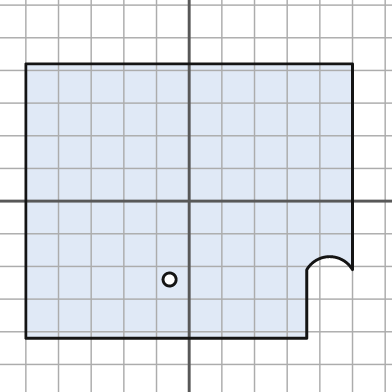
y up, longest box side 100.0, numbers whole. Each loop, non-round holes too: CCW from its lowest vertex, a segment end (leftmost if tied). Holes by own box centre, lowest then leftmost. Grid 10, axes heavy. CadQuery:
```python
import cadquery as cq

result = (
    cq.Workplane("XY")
    .moveTo(-50.0, -42.0)
    .lineTo(36.0, -42.0)
    .lineTo(36.0, -21.0)
    .threePointArc((43.0, -17.0), (50.0, -21.0))
    .lineTo(50.0, 42.0)
    .lineTo(-50.0, 42.0)
    .close()
    .moveTo(-6.0, -24.0)
    .circle(2.0)
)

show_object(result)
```